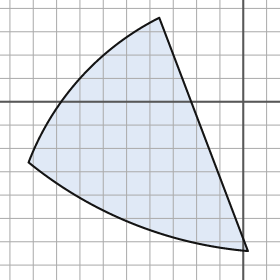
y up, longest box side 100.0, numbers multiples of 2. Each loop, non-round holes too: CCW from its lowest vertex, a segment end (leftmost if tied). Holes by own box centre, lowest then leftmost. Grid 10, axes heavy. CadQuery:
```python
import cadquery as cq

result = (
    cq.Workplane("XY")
    .moveTo(2.0, -64.0)
    .lineTo(-36.0, 36.0)
    .threePointArc((-70.0, 10.0), (-92.0, -26.0))
    .threePointArc((-48.0, -52.0), (2.0, -64.0))
    .close()
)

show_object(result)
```